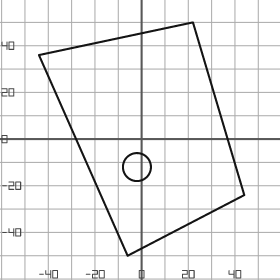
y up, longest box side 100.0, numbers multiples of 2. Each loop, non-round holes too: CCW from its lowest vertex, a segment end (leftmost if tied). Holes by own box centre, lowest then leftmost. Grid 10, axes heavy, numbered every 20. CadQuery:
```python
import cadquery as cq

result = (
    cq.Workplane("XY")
    .moveTo(-6.0, -50.0)
    .lineTo(44.0, -24.0)
    .lineTo(22.0, 50.0)
    .lineTo(-44.0, 36.0)
    .close()
    .moveTo(-2.0, -12.0)
    .circle(6.0)
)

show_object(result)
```